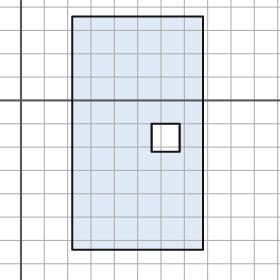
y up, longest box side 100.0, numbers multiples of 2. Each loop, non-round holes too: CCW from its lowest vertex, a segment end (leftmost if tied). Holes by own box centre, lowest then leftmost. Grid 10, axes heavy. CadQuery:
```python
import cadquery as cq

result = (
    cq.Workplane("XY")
    .moveTo(22.0, -64.0)
    .lineTo(78.0, -64.0)
    .lineTo(78.0, 36.0)
    .lineTo(22.0, 36.0)
    .close()
    .moveTo(56.0, -22.0)
    .lineTo(68.0, -22.0)
    .lineTo(68.0, -10.0)
    .lineTo(56.0, -10.0)
    .close()
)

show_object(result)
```